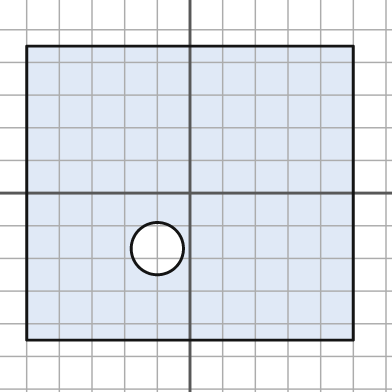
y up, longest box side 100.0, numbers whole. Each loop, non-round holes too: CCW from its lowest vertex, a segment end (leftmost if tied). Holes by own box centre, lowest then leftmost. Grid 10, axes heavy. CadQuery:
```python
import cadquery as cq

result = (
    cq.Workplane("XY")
    .moveTo(-50.0, -45.0)
    .lineTo(50.0, -45.0)
    .lineTo(50.0, 45.0)
    .lineTo(-50.0, 45.0)
    .close()
    .moveTo(-10.0, -17.0)
    .circle(8.0)
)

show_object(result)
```